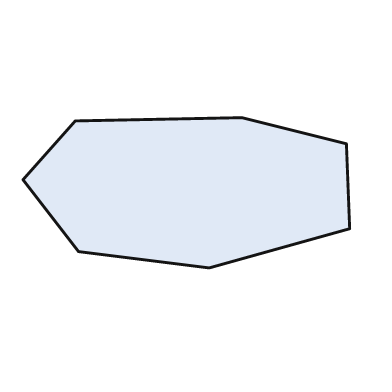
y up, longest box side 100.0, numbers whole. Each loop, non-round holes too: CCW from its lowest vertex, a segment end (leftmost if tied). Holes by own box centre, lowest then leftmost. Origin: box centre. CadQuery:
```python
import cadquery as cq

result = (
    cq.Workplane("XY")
    .moveTo(7.0, -23.0)
    .lineTo(50.0, -11.0)
    .lineTo(49.0, 15.0)
    .lineTo(17.0, 23.0)
    .lineTo(-34.0, 22.0)
    .lineTo(-50.0, 4.0)
    .lineTo(-33.0, -18.0)
    .close()
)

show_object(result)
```